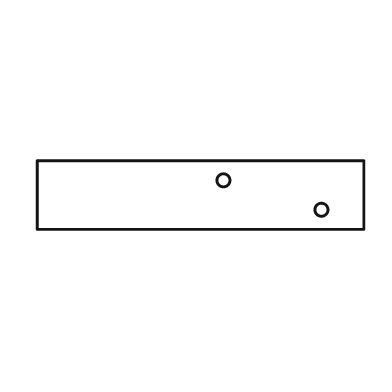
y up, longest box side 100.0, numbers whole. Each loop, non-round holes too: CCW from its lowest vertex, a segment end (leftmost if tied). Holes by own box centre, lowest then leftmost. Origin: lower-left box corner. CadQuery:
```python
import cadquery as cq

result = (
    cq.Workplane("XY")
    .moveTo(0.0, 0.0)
    .lineTo(100.0, 0.0)
    .lineTo(100.0, 21.0)
    .lineTo(0.0, 21.0)
    .close()
    .moveTo(87.0, 6.0)
    .circle(2.0)
    .moveTo(57.0, 15.0)
    .circle(2.0)
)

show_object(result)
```